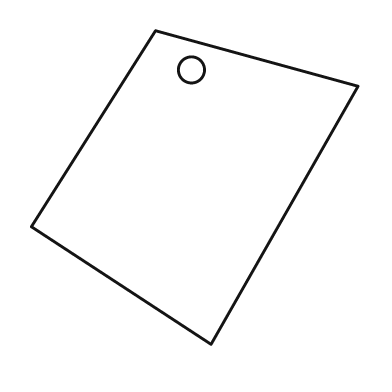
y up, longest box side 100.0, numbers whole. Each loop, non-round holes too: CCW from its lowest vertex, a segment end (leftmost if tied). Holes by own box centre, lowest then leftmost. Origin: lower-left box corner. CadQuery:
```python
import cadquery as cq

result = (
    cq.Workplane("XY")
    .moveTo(55.0, 0.0)
    .lineTo(100.0, 79.0)
    .lineTo(38.0, 96.0)
    .lineTo(0.0, 36.0)
    .close()
    .moveTo(49.0, 84.0)
    .circle(4.0)
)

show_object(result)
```